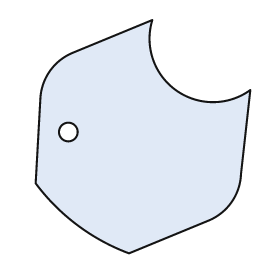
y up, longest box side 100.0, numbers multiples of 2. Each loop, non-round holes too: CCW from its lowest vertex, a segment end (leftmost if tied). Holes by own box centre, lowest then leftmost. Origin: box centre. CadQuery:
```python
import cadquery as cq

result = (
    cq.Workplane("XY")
    .moveTo(-6.0, -50.0)
    .lineTo(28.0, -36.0)
    .threePointArc((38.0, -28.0), (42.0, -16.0))
    .lineTo(46.0, 20.0)
    .threePointArc((14.0, 20.0), (4.0, 50.0))
    .lineTo(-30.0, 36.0)
    .threePointArc((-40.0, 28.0), (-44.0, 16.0))
    .lineTo(-46.0, -20.0)
    .threePointArc((-28.0, -38.0), (-6.0, -50.0))
    .close()
    .moveTo(-32.0, 2.0)
    .circle(4.0)
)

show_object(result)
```